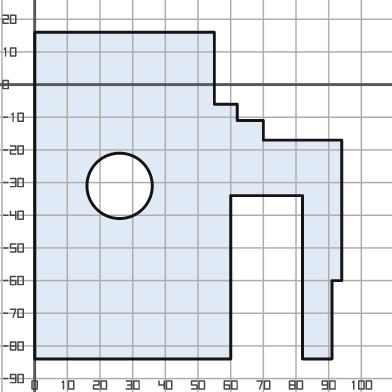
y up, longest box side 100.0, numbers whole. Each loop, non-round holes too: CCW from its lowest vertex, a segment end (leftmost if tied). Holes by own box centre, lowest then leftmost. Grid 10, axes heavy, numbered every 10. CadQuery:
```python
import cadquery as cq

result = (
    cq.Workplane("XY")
    .moveTo(0.0, -84.0)
    .lineTo(60.0, -84.0)
    .lineTo(60.0, -34.0)
    .lineTo(82.0, -34.0)
    .lineTo(82.0, -84.0)
    .lineTo(91.0, -84.0)
    .lineTo(91.0, -60.0)
    .lineTo(94.0, -60.0)
    .lineTo(94.0, -17.0)
    .lineTo(70.0, -17.0)
    .lineTo(70.0, -11.0)
    .lineTo(62.0, -11.0)
    .lineTo(62.0, -6.0)
    .lineTo(55.0, -6.0)
    .lineTo(55.0, 16.0)
    .lineTo(0.0, 16.0)
    .close()
    .moveTo(26.0, -31.0)
    .circle(10.0)
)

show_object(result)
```